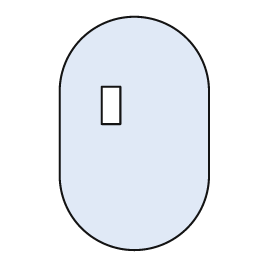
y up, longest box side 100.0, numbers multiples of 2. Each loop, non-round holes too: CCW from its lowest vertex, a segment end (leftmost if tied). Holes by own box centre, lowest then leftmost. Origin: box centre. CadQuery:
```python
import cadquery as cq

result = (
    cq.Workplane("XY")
    .moveTo(-32.0, -18.0)
    .threePointArc((0.0, -50.0), (32.0, -18.0))
    .lineTo(32.0, 18.0)
    .threePointArc((0.0, 50.0), (-32.0, 18.0))
    .close()
    .moveTo(-14.0, 4.0)
    .lineTo(-6.0, 4.0)
    .lineTo(-6.0, 20.0)
    .lineTo(-14.0, 20.0)
    .close()
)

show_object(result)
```